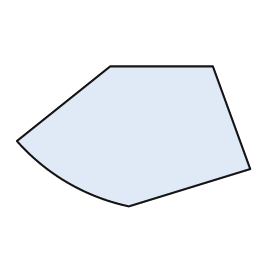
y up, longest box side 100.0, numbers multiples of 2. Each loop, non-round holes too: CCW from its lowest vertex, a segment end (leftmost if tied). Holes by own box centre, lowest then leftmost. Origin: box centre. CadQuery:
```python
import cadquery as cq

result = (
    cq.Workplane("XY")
    .moveTo(-2.0, -30.0)
    .lineTo(50.0, -14.0)
    .lineTo(34.0, 30.0)
    .lineTo(-10.0, 30.0)
    .lineTo(-50.0, -2.0)
    .threePointArc((-28.0, -20.0), (-2.0, -30.0))
    .close()
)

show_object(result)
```